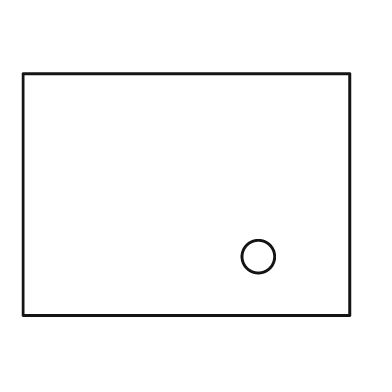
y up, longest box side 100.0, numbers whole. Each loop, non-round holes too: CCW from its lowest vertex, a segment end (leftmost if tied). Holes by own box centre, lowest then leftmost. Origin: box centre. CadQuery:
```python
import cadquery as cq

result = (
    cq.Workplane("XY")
    .moveTo(-50.0, -37.0)
    .lineTo(50.0, -37.0)
    .lineTo(50.0, 37.0)
    .lineTo(-50.0, 37.0)
    .close()
    .moveTo(22.0, -19.0)
    .circle(5.0)
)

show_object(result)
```